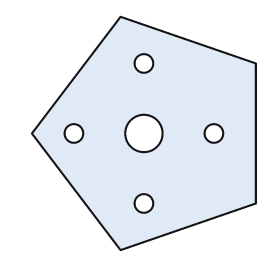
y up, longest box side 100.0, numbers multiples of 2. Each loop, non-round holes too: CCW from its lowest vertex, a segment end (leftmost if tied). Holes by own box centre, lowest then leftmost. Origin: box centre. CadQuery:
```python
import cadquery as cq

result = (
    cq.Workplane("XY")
    .moveTo(-10.0, -50.0)
    .lineTo(48.0, -30.0)
    .lineTo(48.0, 30.0)
    .lineTo(-10.0, 50.0)
    .lineTo(-48.0, 0.0)
    .close()
    .moveTo(0.0, -30.0)
    .circle(4.0)
    .moveTo(-30.0, 0.0)
    .circle(4.0)
    .moveTo(0.0, 0.0)
    .circle(8.0)
    .moveTo(30.0, 0.0)
    .circle(4.0)
    .moveTo(0.0, 30.0)
    .circle(4.0)
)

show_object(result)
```